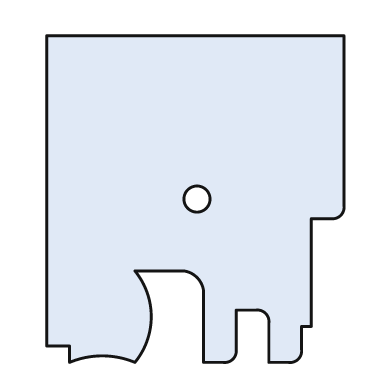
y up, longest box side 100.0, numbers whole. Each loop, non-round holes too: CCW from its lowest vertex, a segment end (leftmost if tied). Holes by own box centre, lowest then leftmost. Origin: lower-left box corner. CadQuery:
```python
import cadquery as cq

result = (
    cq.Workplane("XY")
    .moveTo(7.0, 0.0)
    .threePointArc((17.0, 2.0), (27.0, 0.0))
    .threePointArc((32.0, 14.0), (27.0, 28.0))
    .lineTo(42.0, 28.0)
    .threePointArc((46.0, 26.0), (48.0, 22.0))
    .lineTo(48.0, 0.0)
    .lineTo(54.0, 0.0)
    .threePointArc((57.0, 1.0), (58.0, 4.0))
    .lineTo(58.0, 16.0)
    .lineTo(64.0, 16.0)
    .threePointArc((67.0, 15.0), (68.0, 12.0))
    .lineTo(68.0, 0.0)
    .lineTo(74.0, 0.0)
    .threePointArc((77.0, 1.0), (78.0, 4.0))
    .lineTo(78.0, 11.0)
    .lineTo(81.0, 11.0)
    .lineTo(81.0, 44.0)
    .lineTo(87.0, 44.0)
    .threePointArc((90.0, 45.0), (91.0, 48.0))
    .lineTo(91.0, 100.0)
    .lineTo(0.0, 100.0)
    .lineTo(0.0, 5.0)
    .lineTo(7.0, 5.0)
    .close()
    .moveTo(46.0, 50.0)
    .circle(4.0)
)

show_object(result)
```